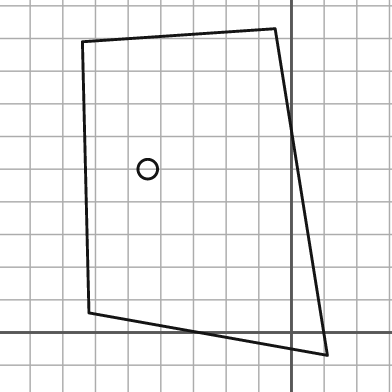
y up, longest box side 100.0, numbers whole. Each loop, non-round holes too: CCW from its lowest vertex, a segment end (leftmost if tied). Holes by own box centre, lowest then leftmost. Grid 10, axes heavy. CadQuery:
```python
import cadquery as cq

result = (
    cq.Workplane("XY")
    .moveTo(11.0, -7.0)
    .lineTo(-5.0, 93.0)
    .lineTo(-64.0, 89.0)
    .lineTo(-62.0, 6.0)
    .close()
    .moveTo(-44.0, 50.0)
    .circle(3.0)
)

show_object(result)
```